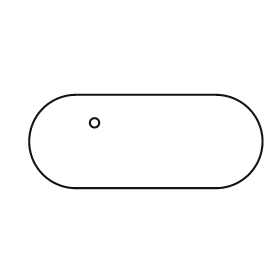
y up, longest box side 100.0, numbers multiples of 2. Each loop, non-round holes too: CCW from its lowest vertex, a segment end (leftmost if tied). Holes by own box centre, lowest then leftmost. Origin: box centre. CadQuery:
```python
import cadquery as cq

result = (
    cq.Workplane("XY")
    .moveTo(-30.0, -20.0)
    .lineTo(30.0, -20.0)
    .threePointArc((50.0, 0.0), (30.0, 20.0))
    .lineTo(-30.0, 20.0)
    .threePointArc((-50.0, 0.0), (-30.0, -20.0))
    .close()
    .moveTo(-22.0, 8.0)
    .circle(2.0)
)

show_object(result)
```